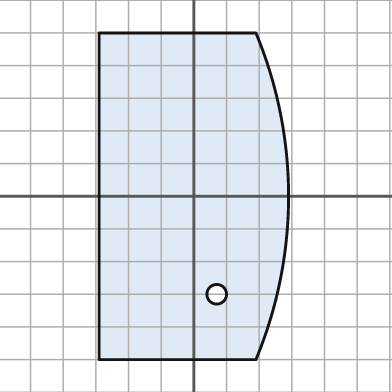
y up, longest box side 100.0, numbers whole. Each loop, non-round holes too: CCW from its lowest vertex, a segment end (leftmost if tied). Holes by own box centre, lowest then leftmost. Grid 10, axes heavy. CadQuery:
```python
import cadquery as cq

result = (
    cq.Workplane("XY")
    .moveTo(-29.0, -50.0)
    .lineTo(19.0, -50.0)
    .threePointArc((29.0, 0.0), (19.0, 50.0))
    .lineTo(-29.0, 50.0)
    .close()
    .moveTo(7.0, -30.0)
    .circle(3.0)
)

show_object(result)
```